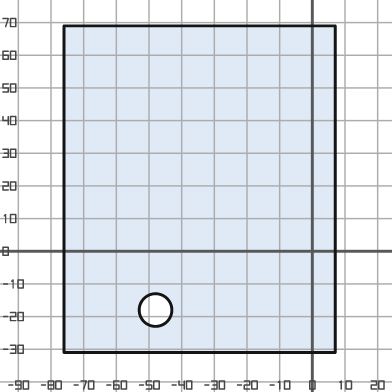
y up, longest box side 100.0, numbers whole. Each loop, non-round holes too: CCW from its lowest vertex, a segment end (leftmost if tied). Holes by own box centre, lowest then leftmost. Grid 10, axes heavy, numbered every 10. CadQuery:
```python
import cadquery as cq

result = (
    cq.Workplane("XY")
    .moveTo(-76.0, -31.0)
    .lineTo(7.0, -31.0)
    .lineTo(7.0, 69.0)
    .lineTo(-76.0, 69.0)
    .close()
    .moveTo(-48.0, -18.0)
    .circle(5.0)
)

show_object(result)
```